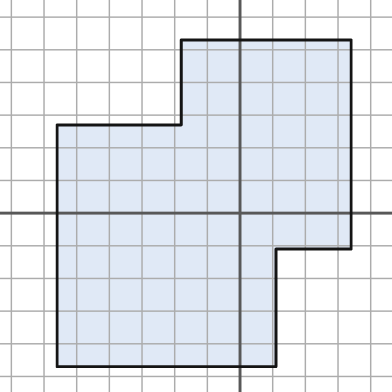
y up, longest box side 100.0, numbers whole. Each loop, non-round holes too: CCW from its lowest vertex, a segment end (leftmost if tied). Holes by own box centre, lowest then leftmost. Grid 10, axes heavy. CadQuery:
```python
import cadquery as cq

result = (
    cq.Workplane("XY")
    .moveTo(-56.0, -47.0)
    .lineTo(11.0, -47.0)
    .lineTo(11.0, -11.0)
    .lineTo(34.0, -11.0)
    .lineTo(34.0, 53.0)
    .lineTo(-18.0, 53.0)
    .lineTo(-18.0, 27.0)
    .lineTo(-56.0, 27.0)
    .close()
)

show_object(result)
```